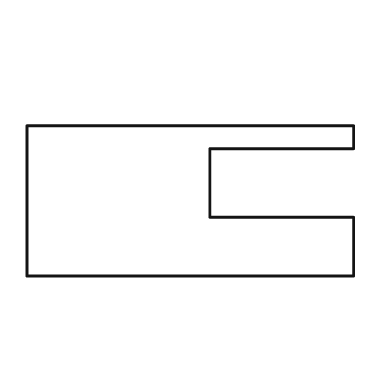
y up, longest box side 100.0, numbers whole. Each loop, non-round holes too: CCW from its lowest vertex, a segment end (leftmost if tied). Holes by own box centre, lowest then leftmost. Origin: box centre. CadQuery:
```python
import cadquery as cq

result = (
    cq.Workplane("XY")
    .moveTo(-50.0, -23.0)
    .lineTo(50.0, -23.0)
    .lineTo(50.0, -5.0)
    .lineTo(6.0, -5.0)
    .lineTo(6.0, 16.0)
    .lineTo(50.0, 16.0)
    .lineTo(50.0, 23.0)
    .lineTo(-50.0, 23.0)
    .close()
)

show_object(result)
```